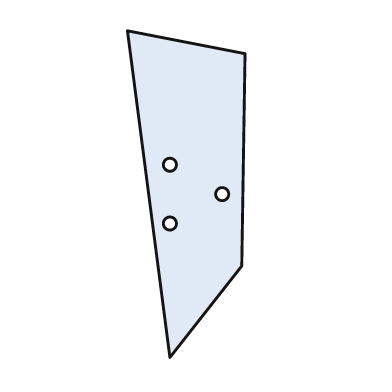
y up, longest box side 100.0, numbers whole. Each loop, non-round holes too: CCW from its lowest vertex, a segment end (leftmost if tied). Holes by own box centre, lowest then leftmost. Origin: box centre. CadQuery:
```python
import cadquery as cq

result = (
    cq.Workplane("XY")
    .moveTo(-5.0, -50.0)
    .lineTo(17.0, -22.0)
    .lineTo(18.0, 43.0)
    .lineTo(-18.0, 50.0)
    .close()
    .moveTo(-5.0, -9.0)
    .circle(2.0)
    .moveTo(11.0, 0.0)
    .circle(2.0)
    .moveTo(-5.0, 9.0)
    .circle(2.0)
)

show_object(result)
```